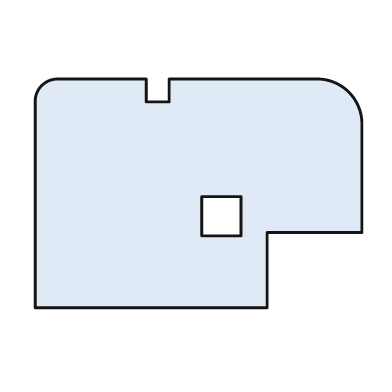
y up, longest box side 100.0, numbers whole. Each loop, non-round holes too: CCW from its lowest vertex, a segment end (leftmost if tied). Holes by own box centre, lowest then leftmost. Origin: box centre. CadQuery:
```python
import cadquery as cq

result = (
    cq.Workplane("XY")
    .moveTo(-50.0, -35.0)
    .lineTo(21.0, -35.0)
    .lineTo(21.0, -12.0)
    .lineTo(50.0, -12.0)
    .lineTo(50.0, 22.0)
    .threePointArc((46.0, 31.0), (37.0, 35.0))
    .lineTo(-9.0, 35.0)
    .lineTo(-9.0, 28.0)
    .lineTo(-16.0, 28.0)
    .lineTo(-16.0, 35.0)
    .lineTo(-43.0, 35.0)
    .threePointArc((-48.0, 33.0), (-50.0, 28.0))
    .close()
    .moveTo(1.0, -13.0)
    .lineTo(13.0, -13.0)
    .lineTo(13.0, -1.0)
    .lineTo(1.0, -1.0)
    .close()
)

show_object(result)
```